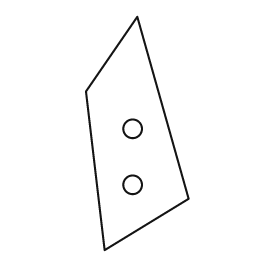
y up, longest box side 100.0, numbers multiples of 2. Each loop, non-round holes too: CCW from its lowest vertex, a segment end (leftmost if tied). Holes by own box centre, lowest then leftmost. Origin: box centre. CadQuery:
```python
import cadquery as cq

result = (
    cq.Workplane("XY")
    .moveTo(-14.0, -50.0)
    .lineTo(22.0, -28.0)
    .lineTo(0.0, 50.0)
    .lineTo(-22.0, 18.0)
    .close()
    .moveTo(-2.0, -22.0)
    .circle(4.0)
    .moveTo(-2.0, 2.0)
    .circle(4.0)
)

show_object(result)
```